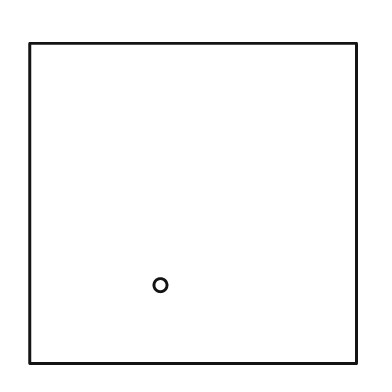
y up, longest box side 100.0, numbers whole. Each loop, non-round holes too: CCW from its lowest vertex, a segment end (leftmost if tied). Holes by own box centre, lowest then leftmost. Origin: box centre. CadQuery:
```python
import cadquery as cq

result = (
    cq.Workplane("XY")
    .moveTo(-50.0, -49.0)
    .lineTo(50.0, -49.0)
    .lineTo(50.0, 49.0)
    .lineTo(-50.0, 49.0)
    .close()
    .moveTo(-10.0, -25.0)
    .circle(2.0)
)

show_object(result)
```